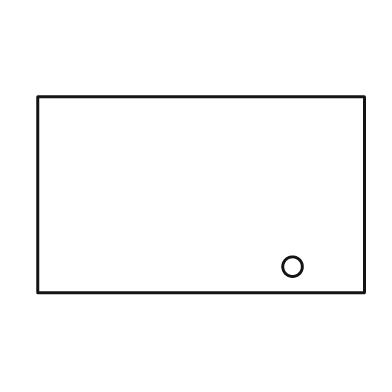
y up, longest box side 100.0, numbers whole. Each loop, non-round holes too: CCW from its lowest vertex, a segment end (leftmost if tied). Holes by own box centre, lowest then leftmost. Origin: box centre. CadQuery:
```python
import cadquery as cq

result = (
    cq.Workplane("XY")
    .moveTo(-50.0, -30.0)
    .lineTo(50.0, -30.0)
    .lineTo(50.0, 30.0)
    .lineTo(-50.0, 30.0)
    .close()
    .moveTo(28.0, -22.0)
    .circle(3.0)
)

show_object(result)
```